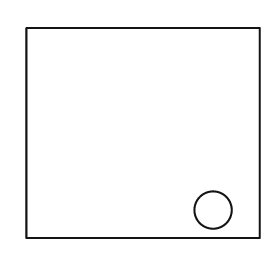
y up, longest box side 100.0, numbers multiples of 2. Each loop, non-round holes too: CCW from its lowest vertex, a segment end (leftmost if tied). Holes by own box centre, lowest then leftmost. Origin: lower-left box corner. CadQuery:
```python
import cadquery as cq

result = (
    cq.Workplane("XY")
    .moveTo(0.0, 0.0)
    .lineTo(100.0, 0.0)
    .lineTo(100.0, 90.0)
    .lineTo(0.0, 90.0)
    .close()
    .moveTo(80.0, 12.0)
    .circle(8.0)
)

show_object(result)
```